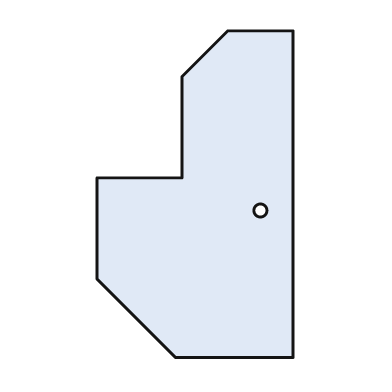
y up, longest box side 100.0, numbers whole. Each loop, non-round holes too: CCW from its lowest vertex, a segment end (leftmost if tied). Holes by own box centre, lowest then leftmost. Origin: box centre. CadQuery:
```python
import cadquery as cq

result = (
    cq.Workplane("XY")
    .moveTo(-6.0, -50.0)
    .lineTo(30.0, -50.0)
    .lineTo(30.0, 50.0)
    .lineTo(10.0, 50.0)
    .lineTo(-4.0, 36.0)
    .lineTo(-4.0, 5.0)
    .lineTo(-30.0, 5.0)
    .lineTo(-30.0, -26.0)
    .close()
    .moveTo(20.0, -5.0)
    .circle(2.0)
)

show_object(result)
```